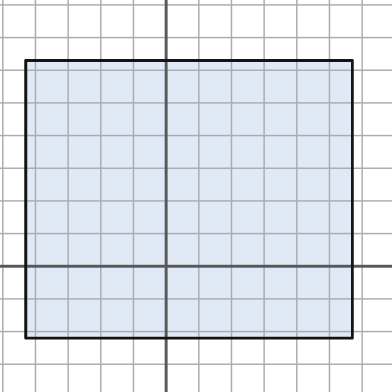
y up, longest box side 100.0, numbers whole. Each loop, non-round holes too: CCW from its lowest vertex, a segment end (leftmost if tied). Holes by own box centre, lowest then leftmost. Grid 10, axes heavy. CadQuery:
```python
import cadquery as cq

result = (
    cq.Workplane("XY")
    .moveTo(-43.0, -22.0)
    .lineTo(57.0, -22.0)
    .lineTo(57.0, 63.0)
    .lineTo(-43.0, 63.0)
    .close()
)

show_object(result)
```